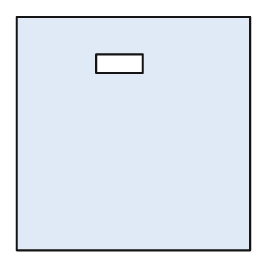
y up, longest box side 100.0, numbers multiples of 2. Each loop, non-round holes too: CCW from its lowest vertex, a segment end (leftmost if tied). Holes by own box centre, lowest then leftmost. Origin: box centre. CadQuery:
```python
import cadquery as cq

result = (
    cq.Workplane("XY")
    .moveTo(-50.0, -50.0)
    .lineTo(50.0, -50.0)
    .lineTo(50.0, 50.0)
    .lineTo(-50.0, 50.0)
    .close()
    .moveTo(-16.0, 26.0)
    .lineTo(4.0, 26.0)
    .lineTo(4.0, 34.0)
    .lineTo(-16.0, 34.0)
    .close()
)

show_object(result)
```